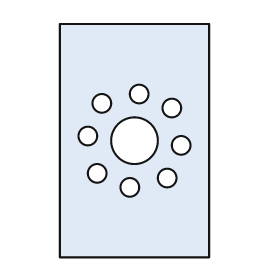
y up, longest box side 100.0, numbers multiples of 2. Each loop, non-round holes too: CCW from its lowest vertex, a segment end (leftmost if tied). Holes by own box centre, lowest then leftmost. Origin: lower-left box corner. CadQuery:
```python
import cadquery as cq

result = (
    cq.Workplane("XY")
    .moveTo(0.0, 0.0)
    .lineTo(64.0, 0.0)
    .lineTo(64.0, 100.0)
    .lineTo(0.0, 100.0)
    .close()
    .moveTo(30.0, 30.0)
    .circle(4.0)
    .moveTo(46.0, 34.0)
    .circle(4.0)
    .moveTo(16.0, 36.0)
    .circle(4.0)
    .moveTo(52.0, 48.0)
    .circle(4.0)
    .moveTo(32.0, 50.0)
    .circle(10.0)
    .moveTo(12.0, 52.0)
    .circle(4.0)
    .moveTo(48.0, 64.0)
    .circle(4.0)
    .moveTo(18.0, 66.0)
    .circle(4.0)
    .moveTo(34.0, 70.0)
    .circle(4.0)
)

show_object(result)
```